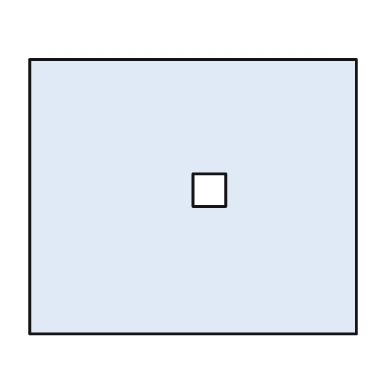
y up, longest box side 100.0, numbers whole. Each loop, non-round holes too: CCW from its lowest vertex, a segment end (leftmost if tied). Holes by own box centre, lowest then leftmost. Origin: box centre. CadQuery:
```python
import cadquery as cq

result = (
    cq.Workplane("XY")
    .moveTo(-50.0, -42.0)
    .lineTo(50.0, -42.0)
    .lineTo(50.0, 42.0)
    .lineTo(-50.0, 42.0)
    .close()
    .moveTo(0.0, -3.0)
    .lineTo(10.0, -3.0)
    .lineTo(10.0, 7.0)
    .lineTo(0.0, 7.0)
    .close()
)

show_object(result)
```